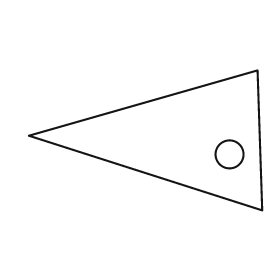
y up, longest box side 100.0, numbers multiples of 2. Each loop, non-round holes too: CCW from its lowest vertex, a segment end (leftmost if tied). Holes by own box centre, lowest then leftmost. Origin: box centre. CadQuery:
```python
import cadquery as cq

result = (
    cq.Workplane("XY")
    .moveTo(50.0, -30.0)
    .lineTo(48.0, 30.0)
    .lineTo(-50.0, 2.0)
    .close()
    .moveTo(36.0, -6.0)
    .circle(6.0)
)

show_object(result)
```